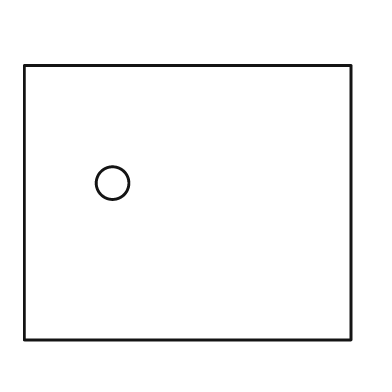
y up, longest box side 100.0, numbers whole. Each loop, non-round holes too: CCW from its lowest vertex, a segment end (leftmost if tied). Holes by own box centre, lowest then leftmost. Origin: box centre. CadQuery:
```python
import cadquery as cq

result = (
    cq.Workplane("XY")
    .moveTo(-50.0, -42.0)
    .lineTo(50.0, -42.0)
    .lineTo(50.0, 42.0)
    .lineTo(-50.0, 42.0)
    .close()
    .moveTo(-23.0, 6.0)
    .circle(5.0)
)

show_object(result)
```